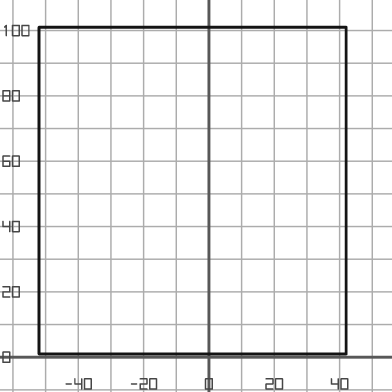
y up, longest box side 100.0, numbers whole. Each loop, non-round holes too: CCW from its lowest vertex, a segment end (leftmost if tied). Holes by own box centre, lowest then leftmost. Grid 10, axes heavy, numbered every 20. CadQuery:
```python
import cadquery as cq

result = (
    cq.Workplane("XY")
    .moveTo(-52.0, 1.0)
    .lineTo(42.0, 1.0)
    .lineTo(42.0, 101.0)
    .lineTo(-52.0, 101.0)
    .close()
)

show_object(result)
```